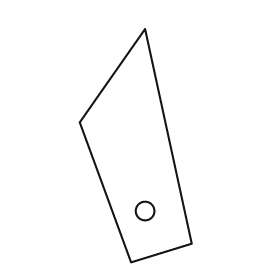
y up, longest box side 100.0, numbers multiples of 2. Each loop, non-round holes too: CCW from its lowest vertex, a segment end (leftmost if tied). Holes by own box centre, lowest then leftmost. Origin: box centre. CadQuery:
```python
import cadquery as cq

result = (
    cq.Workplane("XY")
    .moveTo(-2.0, -50.0)
    .lineTo(24.0, -42.0)
    .lineTo(4.0, 50.0)
    .lineTo(-24.0, 10.0)
    .close()
    .moveTo(4.0, -28.0)
    .circle(4.0)
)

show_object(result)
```